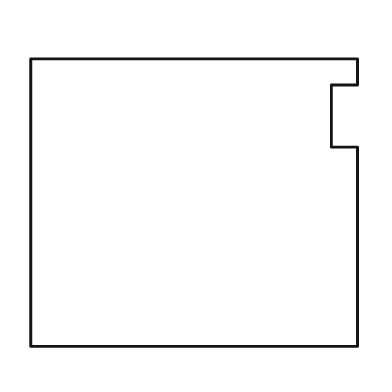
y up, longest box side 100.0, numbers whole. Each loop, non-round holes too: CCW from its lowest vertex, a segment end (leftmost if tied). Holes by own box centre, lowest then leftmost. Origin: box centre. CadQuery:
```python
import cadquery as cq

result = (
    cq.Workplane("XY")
    .moveTo(-50.0, -44.0)
    .lineTo(50.0, -44.0)
    .lineTo(50.0, 17.0)
    .lineTo(42.0, 17.0)
    .lineTo(42.0, 36.0)
    .lineTo(50.0, 36.0)
    .lineTo(50.0, 44.0)
    .lineTo(-50.0, 44.0)
    .close()
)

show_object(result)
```